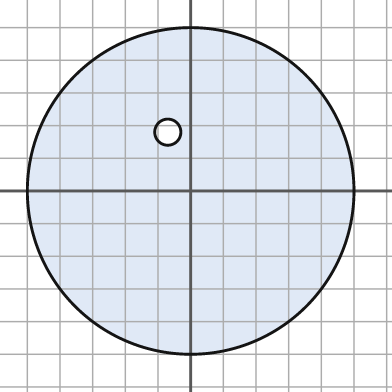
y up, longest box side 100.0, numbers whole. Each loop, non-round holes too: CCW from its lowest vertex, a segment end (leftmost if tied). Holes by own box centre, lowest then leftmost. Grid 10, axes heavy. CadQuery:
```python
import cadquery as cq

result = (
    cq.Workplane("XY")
    .moveTo(0.0, 0.0)
    .circle(50.0)
    .moveTo(-7.0, 18.0)
    .circle(4.0)
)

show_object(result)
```